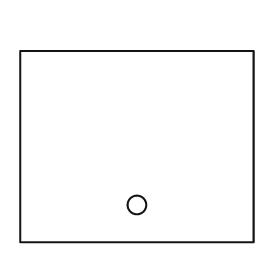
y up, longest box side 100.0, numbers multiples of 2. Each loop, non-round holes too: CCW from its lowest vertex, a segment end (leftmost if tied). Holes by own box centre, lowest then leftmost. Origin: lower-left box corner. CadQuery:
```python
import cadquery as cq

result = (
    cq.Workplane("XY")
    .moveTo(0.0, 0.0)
    .lineTo(100.0, 0.0)
    .lineTo(100.0, 82.0)
    .lineTo(0.0, 82.0)
    .close()
    .moveTo(50.0, 16.0)
    .circle(4.0)
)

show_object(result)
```